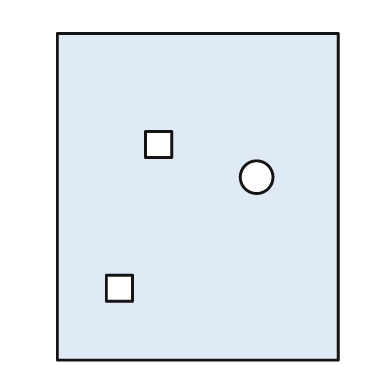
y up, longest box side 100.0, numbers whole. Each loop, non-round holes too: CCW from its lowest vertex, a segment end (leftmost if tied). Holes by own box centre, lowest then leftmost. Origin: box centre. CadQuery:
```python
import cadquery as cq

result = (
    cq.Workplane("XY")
    .moveTo(-43.0, -50.0)
    .lineTo(43.0, -50.0)
    .lineTo(43.0, 50.0)
    .lineTo(-43.0, 50.0)
    .close()
    .moveTo(-28.0, -32.0)
    .lineTo(-20.0, -32.0)
    .lineTo(-20.0, -24.0)
    .lineTo(-28.0, -24.0)
    .close()
    .moveTo(18.0, 6.0)
    .circle(5.0)
    .moveTo(-16.0, 12.0)
    .lineTo(-8.0, 12.0)
    .lineTo(-8.0, 20.0)
    .lineTo(-16.0, 20.0)
    .close()
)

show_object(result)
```